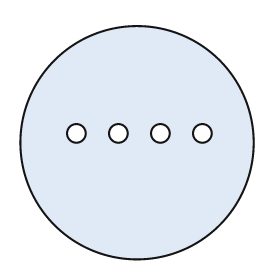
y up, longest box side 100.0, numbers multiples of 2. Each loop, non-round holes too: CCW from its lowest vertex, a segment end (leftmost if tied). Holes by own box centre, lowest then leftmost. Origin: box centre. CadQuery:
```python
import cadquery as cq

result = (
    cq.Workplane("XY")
    .moveTo(0.0, 0.0)
    .circle(50.0)
    .moveTo(-26.0, 4.0)
    .circle(4.0)
    .moveTo(-8.0, 4.0)
    .circle(4.0)
    .moveTo(10.0, 4.0)
    .circle(4.0)
    .moveTo(28.0, 4.0)
    .circle(4.0)
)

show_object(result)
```